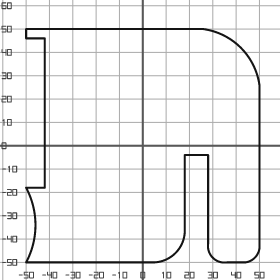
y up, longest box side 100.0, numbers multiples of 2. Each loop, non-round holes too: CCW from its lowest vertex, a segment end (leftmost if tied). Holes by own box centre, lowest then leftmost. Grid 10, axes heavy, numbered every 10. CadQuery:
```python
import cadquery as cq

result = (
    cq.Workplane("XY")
    .moveTo(-50.0, -50.0)
    .lineTo(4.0, -50.0)
    .threePointArc((14.0, -46.0), (18.0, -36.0))
    .lineTo(18.0, -4.0)
    .lineTo(28.0, -4.0)
    .lineTo(28.0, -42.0)
    .threePointArc((30.0, -48.0), (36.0, -50.0))
    .lineTo(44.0, -50.0)
    .threePointArc((48.0, -48.0), (50.0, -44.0))
    .lineTo(50.0, 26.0)
    .threePointArc((42.0, 42.0), (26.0, 50.0))
    .lineTo(-50.0, 50.0)
    .lineTo(-50.0, 46.0)
    .lineTo(-42.0, 46.0)
    .lineTo(-42.0, -18.0)
    .lineTo(-50.0, -18.0)
    .threePointArc((-46.0, -34.0), (-50.0, -50.0))
    .close()
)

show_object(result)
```